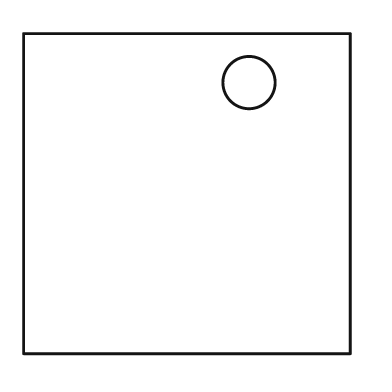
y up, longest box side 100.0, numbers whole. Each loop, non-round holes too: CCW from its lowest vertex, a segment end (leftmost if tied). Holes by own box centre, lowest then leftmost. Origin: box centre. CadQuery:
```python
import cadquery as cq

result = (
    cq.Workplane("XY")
    .moveTo(-50.0, -49.0)
    .lineTo(50.0, -49.0)
    .lineTo(50.0, 49.0)
    .lineTo(-50.0, 49.0)
    .close()
    .moveTo(19.0, 34.0)
    .circle(8.0)
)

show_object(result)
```